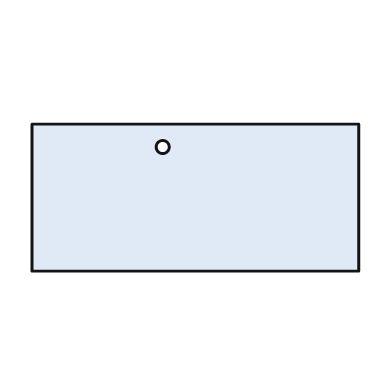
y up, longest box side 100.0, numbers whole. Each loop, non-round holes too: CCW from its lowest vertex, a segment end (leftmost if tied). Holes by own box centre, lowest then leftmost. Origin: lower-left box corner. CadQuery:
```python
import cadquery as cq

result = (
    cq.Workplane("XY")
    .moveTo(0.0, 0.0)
    .lineTo(100.0, 0.0)
    .lineTo(100.0, 45.0)
    .lineTo(0.0, 45.0)
    .close()
    .moveTo(40.0, 38.0)
    .circle(2.0)
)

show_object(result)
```